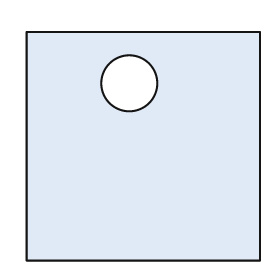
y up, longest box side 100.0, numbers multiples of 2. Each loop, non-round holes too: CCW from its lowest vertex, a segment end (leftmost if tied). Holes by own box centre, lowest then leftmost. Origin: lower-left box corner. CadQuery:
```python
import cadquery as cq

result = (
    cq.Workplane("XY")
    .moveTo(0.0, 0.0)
    .lineTo(100.0, 0.0)
    .lineTo(100.0, 98.0)
    .lineTo(0.0, 98.0)
    .close()
    .moveTo(44.0, 76.0)
    .circle(12.0)
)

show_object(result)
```